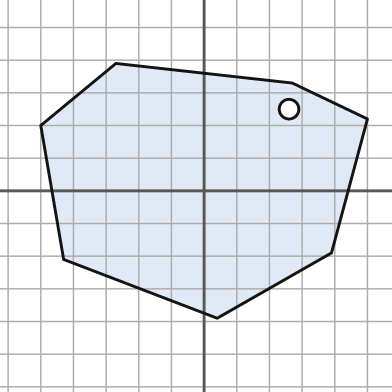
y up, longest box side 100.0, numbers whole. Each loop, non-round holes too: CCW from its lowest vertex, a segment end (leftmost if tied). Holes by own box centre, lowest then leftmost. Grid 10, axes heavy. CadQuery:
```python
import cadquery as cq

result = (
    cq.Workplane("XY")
    .moveTo(4.0, -39.0)
    .lineTo(39.0, -19.0)
    .lineTo(50.0, 22.0)
    .lineTo(27.0, 33.0)
    .lineTo(-27.0, 39.0)
    .lineTo(-50.0, 20.0)
    .lineTo(-43.0, -21.0)
    .close()
    .moveTo(26.0, 25.0)
    .circle(3.0)
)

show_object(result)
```